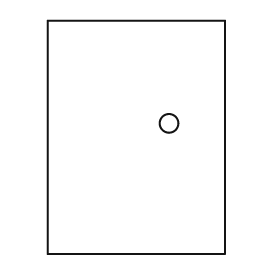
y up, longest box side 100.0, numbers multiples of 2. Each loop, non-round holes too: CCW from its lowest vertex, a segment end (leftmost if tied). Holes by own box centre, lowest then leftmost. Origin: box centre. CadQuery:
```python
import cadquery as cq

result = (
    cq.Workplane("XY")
    .moveTo(-38.0, -50.0)
    .lineTo(38.0, -50.0)
    .lineTo(38.0, 50.0)
    .lineTo(-38.0, 50.0)
    .close()
    .moveTo(14.0, 6.0)
    .circle(4.0)
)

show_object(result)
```